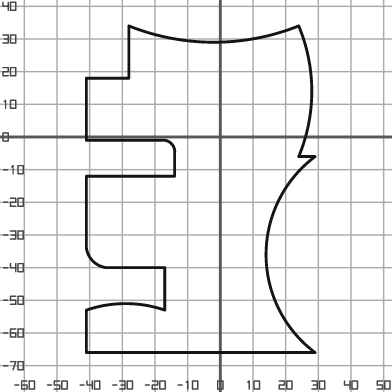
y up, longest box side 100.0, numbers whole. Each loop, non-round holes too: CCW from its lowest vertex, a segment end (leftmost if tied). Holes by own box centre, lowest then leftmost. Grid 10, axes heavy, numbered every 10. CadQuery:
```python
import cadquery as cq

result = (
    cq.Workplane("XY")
    .moveTo(-41.0, -66.0)
    .lineTo(29.0, -66.0)
    .threePointArc((14.0, -36.0), (29.0, -6.0))
    .lineTo(24.0, -6.0)
    .threePointArc((28.0, 14.0), (24.0, 34.0))
    .threePointArc((-2.0, 29.0), (-28.0, 34.0))
    .lineTo(-28.0, 18.0)
    .lineTo(-41.0, 18.0)
    .lineTo(-41.0, -1.0)
    .lineTo(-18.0, -1.0)
    .threePointArc((-15.0, -2.0), (-14.0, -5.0))
    .lineTo(-14.0, -12.0)
    .lineTo(-41.0, -12.0)
    .lineTo(-41.0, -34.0)
    .threePointArc((-39.0, -38.0), (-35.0, -40.0))
    .lineTo(-17.0, -40.0)
    .lineTo(-17.0, -53.0)
    .threePointArc((-29.0, -51.0), (-41.0, -53.0))
    .close()
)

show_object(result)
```